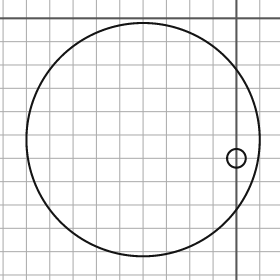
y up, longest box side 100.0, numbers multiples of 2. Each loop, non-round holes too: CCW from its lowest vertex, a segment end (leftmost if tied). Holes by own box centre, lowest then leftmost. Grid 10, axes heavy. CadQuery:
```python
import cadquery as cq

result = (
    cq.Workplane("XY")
    .moveTo(-40.0, -52.0)
    .circle(50.0)
    .moveTo(0.0, -60.0)
    .circle(4.0)
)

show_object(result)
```